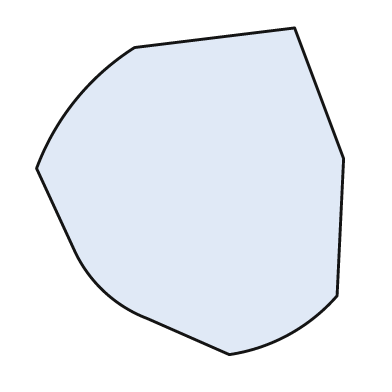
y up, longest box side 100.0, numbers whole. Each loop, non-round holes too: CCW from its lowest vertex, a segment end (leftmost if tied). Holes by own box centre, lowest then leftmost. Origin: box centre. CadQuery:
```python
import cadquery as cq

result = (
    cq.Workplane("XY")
    .moveTo(12.0, -50.0)
    .threePointArc((30.0, -44.0), (45.0, -32.0))
    .lineTo(47.0, 10.0)
    .lineTo(32.0, 50.0)
    .lineTo(-17.0, 44.0)
    .threePointArc((-35.0, 28.0), (-47.0, 7.0))
    .lineTo(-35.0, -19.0)
    .threePointArc((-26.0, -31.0), (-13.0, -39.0))
    .close()
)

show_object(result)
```